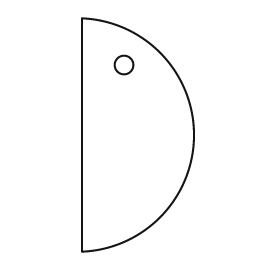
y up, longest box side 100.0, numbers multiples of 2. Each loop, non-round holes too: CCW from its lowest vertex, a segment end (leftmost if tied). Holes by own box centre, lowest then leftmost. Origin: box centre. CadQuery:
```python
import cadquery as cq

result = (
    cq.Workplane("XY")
    .moveTo(-24.0, -50.0)
    .threePointArc((24.0, 0.0), (-24.0, 50.0))
    .close()
    .moveTo(-6.0, 30.0)
    .circle(4.0)
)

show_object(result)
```